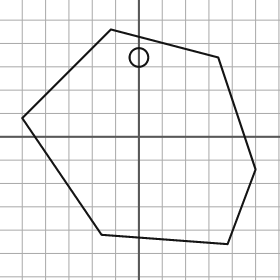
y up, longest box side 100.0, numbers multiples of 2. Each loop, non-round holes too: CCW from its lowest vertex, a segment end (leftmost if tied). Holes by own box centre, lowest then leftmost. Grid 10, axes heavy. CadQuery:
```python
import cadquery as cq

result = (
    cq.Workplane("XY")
    .moveTo(38.0, -46.0)
    .lineTo(50.0, -14.0)
    .lineTo(34.0, 34.0)
    .lineTo(-12.0, 46.0)
    .lineTo(-50.0, 8.0)
    .lineTo(-16.0, -42.0)
    .close()
    .moveTo(0.0, 34.0)
    .circle(4.0)
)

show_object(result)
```